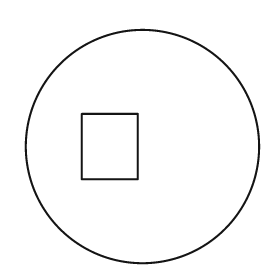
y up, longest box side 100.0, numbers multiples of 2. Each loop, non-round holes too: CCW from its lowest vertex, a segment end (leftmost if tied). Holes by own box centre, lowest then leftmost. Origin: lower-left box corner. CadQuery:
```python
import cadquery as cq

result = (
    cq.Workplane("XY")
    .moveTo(50.0, 50.0)
    .circle(50.0)
    .moveTo(24.0, 36.0)
    .lineTo(48.0, 36.0)
    .lineTo(48.0, 64.0)
    .lineTo(24.0, 64.0)
    .close()
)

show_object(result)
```